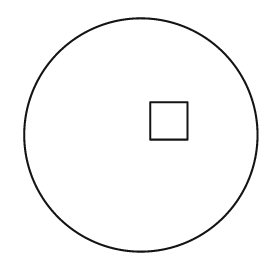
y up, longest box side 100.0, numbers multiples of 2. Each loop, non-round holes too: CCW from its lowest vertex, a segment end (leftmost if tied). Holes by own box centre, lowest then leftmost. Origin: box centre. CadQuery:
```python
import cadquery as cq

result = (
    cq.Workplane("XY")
    .moveTo(0.0, 0.0)
    .circle(50.0)
    .moveTo(4.0, -2.0)
    .lineTo(20.0, -2.0)
    .lineTo(20.0, 14.0)
    .lineTo(4.0, 14.0)
    .close()
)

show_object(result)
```